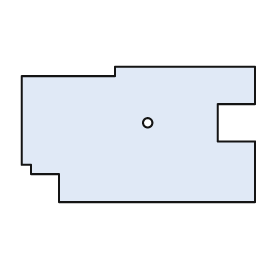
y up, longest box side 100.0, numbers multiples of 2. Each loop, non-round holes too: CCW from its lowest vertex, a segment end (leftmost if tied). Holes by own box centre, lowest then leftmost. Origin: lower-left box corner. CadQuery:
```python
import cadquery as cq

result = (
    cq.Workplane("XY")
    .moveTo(16.0, 0.0)
    .lineTo(100.0, 0.0)
    .lineTo(100.0, 26.0)
    .lineTo(84.0, 26.0)
    .lineTo(84.0, 42.0)
    .lineTo(100.0, 42.0)
    .lineTo(100.0, 58.0)
    .lineTo(40.0, 58.0)
    .lineTo(40.0, 54.0)
    .lineTo(0.0, 54.0)
    .lineTo(0.0, 16.0)
    .lineTo(4.0, 16.0)
    .lineTo(4.0, 12.0)
    .lineTo(16.0, 12.0)
    .close()
    .moveTo(54.0, 34.0)
    .circle(2.0)
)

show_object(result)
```